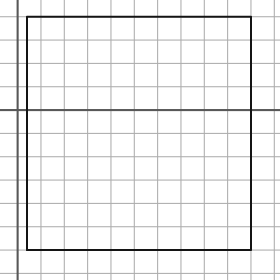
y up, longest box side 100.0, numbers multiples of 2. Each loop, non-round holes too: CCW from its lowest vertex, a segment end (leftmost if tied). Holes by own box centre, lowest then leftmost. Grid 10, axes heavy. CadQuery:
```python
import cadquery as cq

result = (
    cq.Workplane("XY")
    .moveTo(4.0, -60.0)
    .lineTo(100.0, -60.0)
    .lineTo(100.0, 40.0)
    .lineTo(4.0, 40.0)
    .close()
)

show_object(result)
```